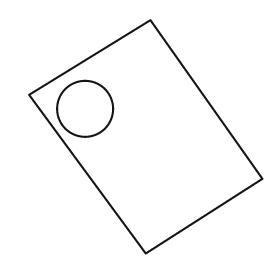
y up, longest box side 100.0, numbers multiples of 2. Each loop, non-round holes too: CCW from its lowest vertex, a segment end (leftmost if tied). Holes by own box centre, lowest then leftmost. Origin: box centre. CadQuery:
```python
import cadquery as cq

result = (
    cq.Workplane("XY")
    .moveTo(0.0, -50.0)
    .lineTo(50.0, -18.0)
    .lineTo(2.0, 50.0)
    .lineTo(-50.0, 18.0)
    .close()
    .moveTo(-26.0, 12.0)
    .circle(12.0)
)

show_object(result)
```